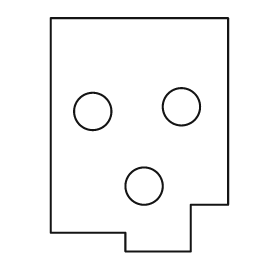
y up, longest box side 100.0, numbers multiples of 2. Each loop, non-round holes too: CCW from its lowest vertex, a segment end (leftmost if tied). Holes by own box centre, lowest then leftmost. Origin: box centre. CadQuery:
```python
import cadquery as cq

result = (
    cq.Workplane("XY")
    .moveTo(-6.0, -50.0)
    .lineTo(22.0, -50.0)
    .lineTo(22.0, -30.0)
    .lineTo(38.0, -30.0)
    .lineTo(38.0, 50.0)
    .lineTo(-38.0, 50.0)
    .lineTo(-38.0, -42.0)
    .lineTo(-6.0, -42.0)
    .close()
    .moveTo(2.0, -22.0)
    .circle(8.0)
    .moveTo(-20.0, 10.0)
    .circle(8.0)
    .moveTo(18.0, 12.0)
    .circle(8.0)
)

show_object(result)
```